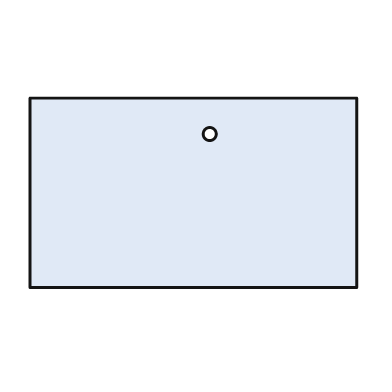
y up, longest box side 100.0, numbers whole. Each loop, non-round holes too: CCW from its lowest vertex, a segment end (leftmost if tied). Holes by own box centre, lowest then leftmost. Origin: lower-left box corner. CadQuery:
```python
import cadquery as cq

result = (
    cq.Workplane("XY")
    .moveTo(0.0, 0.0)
    .lineTo(100.0, 0.0)
    .lineTo(100.0, 58.0)
    .lineTo(0.0, 58.0)
    .close()
    .moveTo(55.0, 47.0)
    .circle(2.0)
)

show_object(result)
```